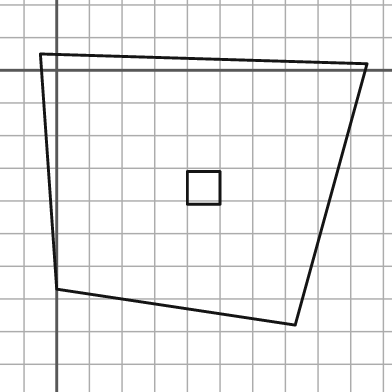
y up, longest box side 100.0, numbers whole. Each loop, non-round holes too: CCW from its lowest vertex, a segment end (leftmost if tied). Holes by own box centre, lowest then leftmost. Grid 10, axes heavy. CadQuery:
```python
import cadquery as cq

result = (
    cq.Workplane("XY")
    .moveTo(73.0, -78.0)
    .lineTo(95.0, 2.0)
    .lineTo(-5.0, 5.0)
    .lineTo(0.0, -67.0)
    .close()
    .moveTo(40.0, -41.0)
    .lineTo(50.0, -41.0)
    .lineTo(50.0, -31.0)
    .lineTo(40.0, -31.0)
    .close()
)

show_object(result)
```